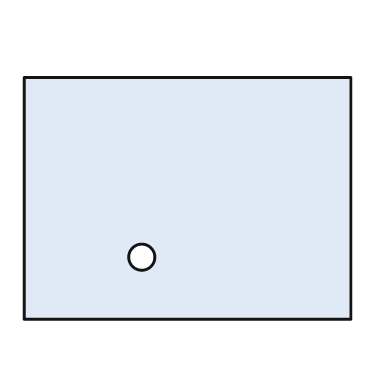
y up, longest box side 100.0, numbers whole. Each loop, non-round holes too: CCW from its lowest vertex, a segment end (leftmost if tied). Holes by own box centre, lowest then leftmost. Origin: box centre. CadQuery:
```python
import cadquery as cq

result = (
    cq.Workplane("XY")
    .moveTo(-50.0, -37.0)
    .lineTo(50.0, -37.0)
    .lineTo(50.0, 37.0)
    .lineTo(-50.0, 37.0)
    .close()
    .moveTo(-14.0, -18.0)
    .circle(4.0)
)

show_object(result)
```